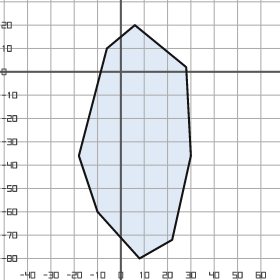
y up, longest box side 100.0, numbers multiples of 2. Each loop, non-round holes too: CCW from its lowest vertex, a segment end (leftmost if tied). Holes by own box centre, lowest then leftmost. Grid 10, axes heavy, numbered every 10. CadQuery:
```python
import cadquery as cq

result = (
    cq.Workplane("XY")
    .moveTo(8.0, -80.0)
    .lineTo(22.0, -72.0)
    .lineTo(30.0, -36.0)
    .lineTo(28.0, 2.0)
    .lineTo(6.0, 20.0)
    .lineTo(-6.0, 10.0)
    .lineTo(-18.0, -36.0)
    .lineTo(-10.0, -60.0)
    .close()
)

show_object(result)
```